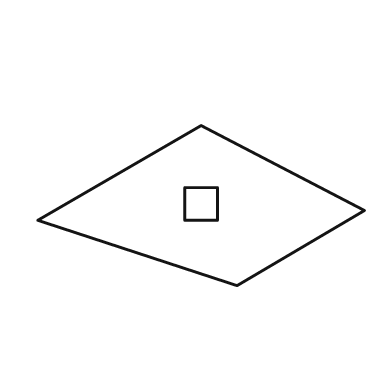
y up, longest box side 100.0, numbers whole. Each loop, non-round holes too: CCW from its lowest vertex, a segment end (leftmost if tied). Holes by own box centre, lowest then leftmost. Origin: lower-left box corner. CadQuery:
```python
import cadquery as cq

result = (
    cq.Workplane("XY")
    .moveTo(61.0, 0.0)
    .lineTo(100.0, 23.0)
    .lineTo(50.0, 49.0)
    .lineTo(0.0, 20.0)
    .close()
    .moveTo(45.0, 20.0)
    .lineTo(55.0, 20.0)
    .lineTo(55.0, 30.0)
    .lineTo(45.0, 30.0)
    .close()
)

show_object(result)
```